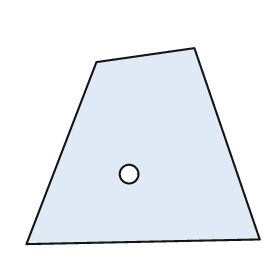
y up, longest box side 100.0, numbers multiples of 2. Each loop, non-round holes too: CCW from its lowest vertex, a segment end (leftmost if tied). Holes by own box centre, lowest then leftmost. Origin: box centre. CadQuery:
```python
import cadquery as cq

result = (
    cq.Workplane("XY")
    .moveTo(-50.0, -42.0)
    .lineTo(50.0, -40.0)
    .lineTo(22.0, 42.0)
    .lineTo(-20.0, 36.0)
    .close()
    .moveTo(-6.0, -12.0)
    .circle(4.0)
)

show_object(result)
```